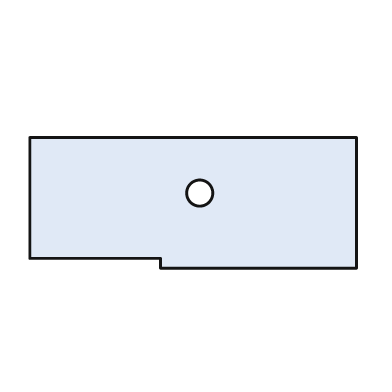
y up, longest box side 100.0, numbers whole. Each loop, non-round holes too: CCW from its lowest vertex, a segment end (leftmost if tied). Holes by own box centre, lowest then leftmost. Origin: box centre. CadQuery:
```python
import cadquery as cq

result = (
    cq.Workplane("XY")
    .moveTo(-10.0, -20.0)
    .lineTo(50.0, -20.0)
    .lineTo(50.0, 20.0)
    .lineTo(-50.0, 20.0)
    .lineTo(-50.0, -17.0)
    .lineTo(-10.0, -17.0)
    .close()
    .moveTo(2.0, 3.0)
    .circle(4.0)
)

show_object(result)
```